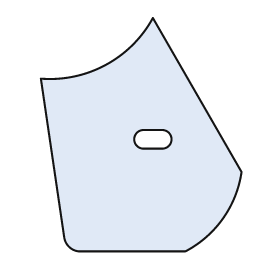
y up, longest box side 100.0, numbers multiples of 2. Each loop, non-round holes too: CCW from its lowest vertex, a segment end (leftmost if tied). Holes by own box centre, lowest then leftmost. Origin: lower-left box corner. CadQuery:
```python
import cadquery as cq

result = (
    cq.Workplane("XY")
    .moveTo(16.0, 0.0)
    .lineTo(62.0, 0.0)
    .threePointArc((78.0, 14.0), (86.0, 34.0))
    .lineTo(48.0, 100.0)
    .threePointArc((28.0, 80.0), (0.0, 74.0))
    .lineTo(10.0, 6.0)
    .threePointArc((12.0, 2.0), (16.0, 0.0))
    .close()
    .moveTo(44.0, 44.0)
    .lineTo(52.0, 44.0)
    .threePointArc((56.0, 48.0), (52.0, 52.0))
    .lineTo(44.0, 52.0)
    .threePointArc((40.0, 48.0), (44.0, 44.0))
    .close()
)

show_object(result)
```